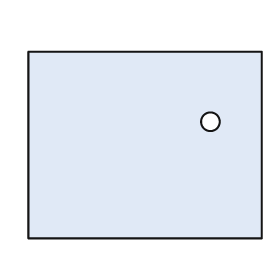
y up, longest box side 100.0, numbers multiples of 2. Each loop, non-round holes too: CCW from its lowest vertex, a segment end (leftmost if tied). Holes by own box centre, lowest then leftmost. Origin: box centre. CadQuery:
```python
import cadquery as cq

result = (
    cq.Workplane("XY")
    .moveTo(-50.0, -40.0)
    .lineTo(50.0, -40.0)
    .lineTo(50.0, 40.0)
    .lineTo(-50.0, 40.0)
    .close()
    .moveTo(28.0, 10.0)
    .circle(4.0)
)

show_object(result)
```